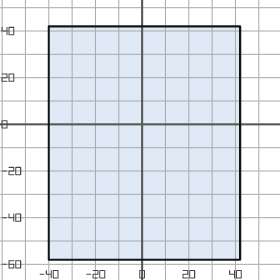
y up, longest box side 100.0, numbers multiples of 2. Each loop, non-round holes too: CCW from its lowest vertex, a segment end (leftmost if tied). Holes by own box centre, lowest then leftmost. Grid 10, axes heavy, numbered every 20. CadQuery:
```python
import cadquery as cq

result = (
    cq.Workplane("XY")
    .moveTo(-40.0, -58.0)
    .lineTo(42.0, -58.0)
    .lineTo(42.0, 42.0)
    .lineTo(-40.0, 42.0)
    .close()
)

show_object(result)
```